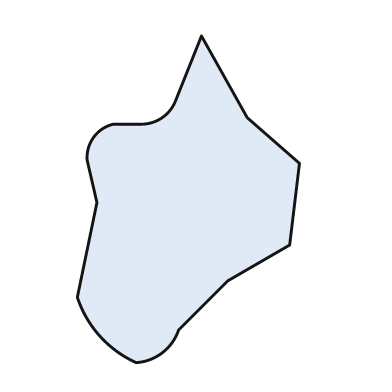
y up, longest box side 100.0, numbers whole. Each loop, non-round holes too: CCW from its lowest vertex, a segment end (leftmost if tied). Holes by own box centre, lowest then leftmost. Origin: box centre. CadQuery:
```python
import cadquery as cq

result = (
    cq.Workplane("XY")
    .moveTo(-16.0, -50.0)
    .threePointArc((-8.0, -47.0), (-3.0, -40.0))
    .lineTo(12.0, -25.0)
    .lineTo(31.0, -14.0)
    .lineTo(34.0, 11.0)
    .lineTo(18.0, 25.0)
    .lineTo(4.0, 50.0)
    .lineTo(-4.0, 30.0)
    .threePointArc((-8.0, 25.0), (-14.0, 23.0))
    .lineTo(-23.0, 23.0)
    .threePointArc((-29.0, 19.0), (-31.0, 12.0))
    .lineTo(-28.0, -1.0)
    .lineTo(-34.0, -30.0)
    .threePointArc((-27.0, -42.0), (-16.0, -50.0))
    .close()
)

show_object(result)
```